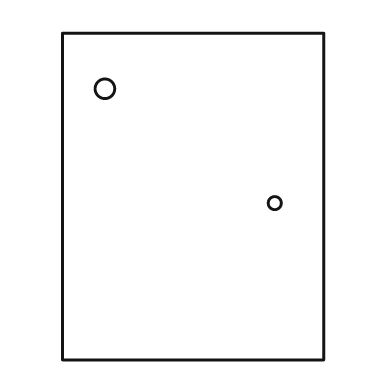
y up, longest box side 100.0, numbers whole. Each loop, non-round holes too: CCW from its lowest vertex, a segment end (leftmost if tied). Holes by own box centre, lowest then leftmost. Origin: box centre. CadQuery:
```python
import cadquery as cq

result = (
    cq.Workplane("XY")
    .moveTo(-40.0, -50.0)
    .lineTo(40.0, -50.0)
    .lineTo(40.0, 50.0)
    .lineTo(-40.0, 50.0)
    .close()
    .moveTo(25.0, -2.0)
    .circle(2.0)
    .moveTo(-27.0, 33.0)
    .circle(3.0)
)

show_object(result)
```